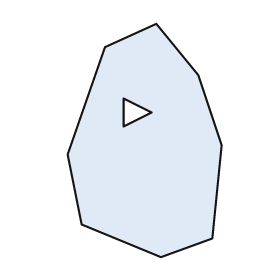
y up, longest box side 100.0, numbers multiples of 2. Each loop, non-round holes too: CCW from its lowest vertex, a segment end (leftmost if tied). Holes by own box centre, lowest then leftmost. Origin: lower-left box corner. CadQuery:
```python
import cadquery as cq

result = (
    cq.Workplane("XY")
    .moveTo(40.0, 0.0)
    .lineTo(62.0, 8.0)
    .lineTo(66.0, 48.0)
    .lineTo(56.0, 78.0)
    .lineTo(38.0, 100.0)
    .lineTo(16.0, 90.0)
    .lineTo(0.0, 44.0)
    .lineTo(6.0, 14.0)
    .close()
    .moveTo(24.0, 56.0)
    .lineTo(36.0, 62.0)
    .lineTo(24.0, 68.0)
    .close()
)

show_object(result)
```